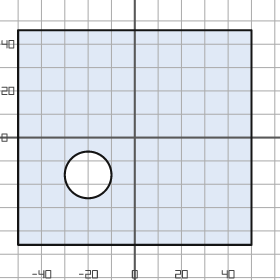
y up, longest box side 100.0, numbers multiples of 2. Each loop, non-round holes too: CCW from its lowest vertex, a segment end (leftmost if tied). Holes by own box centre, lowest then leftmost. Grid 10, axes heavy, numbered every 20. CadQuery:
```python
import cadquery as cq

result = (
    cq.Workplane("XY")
    .moveTo(-50.0, -46.0)
    .lineTo(50.0, -46.0)
    .lineTo(50.0, 46.0)
    .lineTo(-50.0, 46.0)
    .close()
    .moveTo(-20.0, -16.0)
    .circle(10.0)
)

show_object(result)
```